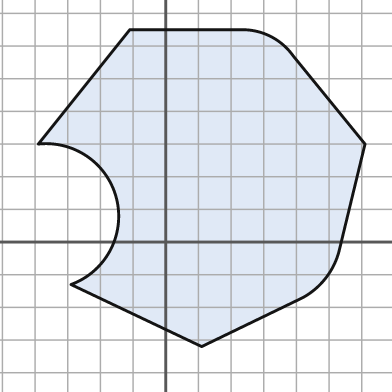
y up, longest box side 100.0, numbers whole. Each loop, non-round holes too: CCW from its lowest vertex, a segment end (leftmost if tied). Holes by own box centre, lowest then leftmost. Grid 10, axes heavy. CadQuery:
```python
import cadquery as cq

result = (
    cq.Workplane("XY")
    .moveTo(11.0, -32.0)
    .lineTo(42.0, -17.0)
    .threePointArc((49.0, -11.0), (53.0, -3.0))
    .lineTo(61.0, 30.0)
    .lineTo(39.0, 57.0)
    .threePointArc((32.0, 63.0), (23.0, 65.0))
    .lineTo(-11.0, 65.0)
    .lineTo(-39.0, 30.0)
    .threePointArc((-15.0, 13.0), (-29.0, -13.0))
    .close()
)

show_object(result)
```